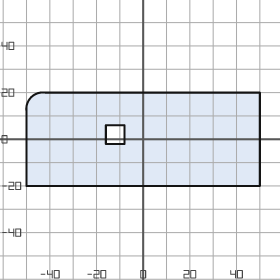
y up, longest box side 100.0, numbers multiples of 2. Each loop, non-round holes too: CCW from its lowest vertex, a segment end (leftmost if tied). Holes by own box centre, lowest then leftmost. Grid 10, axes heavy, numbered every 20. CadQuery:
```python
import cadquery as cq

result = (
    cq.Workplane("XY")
    .moveTo(-50.0, -20.0)
    .lineTo(50.0, -20.0)
    .lineTo(50.0, 20.0)
    .lineTo(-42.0, 20.0)
    .threePointArc((-48.0, 18.0), (-50.0, 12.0))
    .close()
    .moveTo(-16.0, -2.0)
    .lineTo(-8.0, -2.0)
    .lineTo(-8.0, 6.0)
    .lineTo(-16.0, 6.0)
    .close()
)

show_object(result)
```